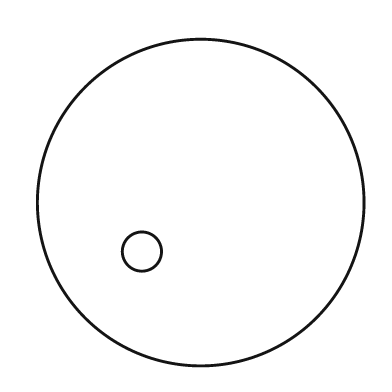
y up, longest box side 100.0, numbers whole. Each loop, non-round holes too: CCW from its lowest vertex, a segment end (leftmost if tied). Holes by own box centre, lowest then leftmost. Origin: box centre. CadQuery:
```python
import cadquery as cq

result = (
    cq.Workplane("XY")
    .moveTo(0.0, 0.0)
    .circle(50.0)
    .moveTo(-18.0, -15.0)
    .circle(6.0)
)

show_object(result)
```